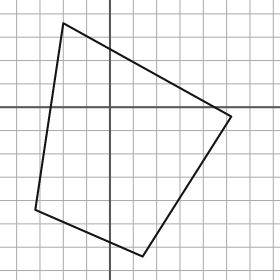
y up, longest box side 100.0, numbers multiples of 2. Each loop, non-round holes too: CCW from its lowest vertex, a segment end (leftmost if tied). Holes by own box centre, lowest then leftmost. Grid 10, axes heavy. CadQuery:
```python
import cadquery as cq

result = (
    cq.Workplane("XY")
    .moveTo(14.0, -64.0)
    .lineTo(52.0, -4.0)
    .lineTo(-20.0, 36.0)
    .lineTo(-32.0, -44.0)
    .close()
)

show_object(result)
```